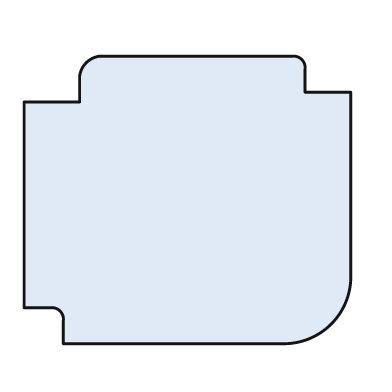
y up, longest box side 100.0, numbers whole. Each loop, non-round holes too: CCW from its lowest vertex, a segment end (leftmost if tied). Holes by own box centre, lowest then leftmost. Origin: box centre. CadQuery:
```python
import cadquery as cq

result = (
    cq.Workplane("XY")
    .moveTo(-38.0, -44.0)
    .lineTo(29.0, -44.0)
    .threePointArc((44.0, -38.0), (50.0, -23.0))
    .lineTo(50.0, 33.0)
    .lineTo(36.0, 33.0)
    .lineTo(36.0, 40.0)
    .threePointArc((35.0, 43.0), (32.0, 44.0))
    .lineTo(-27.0, 44.0)
    .threePointArc((-31.0, 42.0), (-33.0, 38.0))
    .lineTo(-33.0, 30.0)
    .lineTo(-50.0, 30.0)
    .lineTo(-50.0, -33.0)
    .lineTo(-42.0, -33.0)
    .threePointArc((-39.0, -34.0), (-38.0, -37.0))
    .close()
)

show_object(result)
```